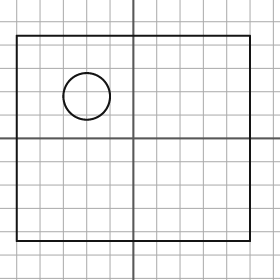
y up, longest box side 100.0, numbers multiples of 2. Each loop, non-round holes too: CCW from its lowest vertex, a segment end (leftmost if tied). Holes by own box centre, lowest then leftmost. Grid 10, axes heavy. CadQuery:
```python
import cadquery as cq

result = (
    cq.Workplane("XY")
    .moveTo(-50.0, -44.0)
    .lineTo(50.0, -44.0)
    .lineTo(50.0, 44.0)
    .lineTo(-50.0, 44.0)
    .close()
    .moveTo(-20.0, 18.0)
    .circle(10.0)
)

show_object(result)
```